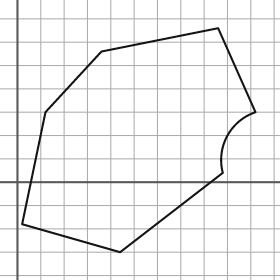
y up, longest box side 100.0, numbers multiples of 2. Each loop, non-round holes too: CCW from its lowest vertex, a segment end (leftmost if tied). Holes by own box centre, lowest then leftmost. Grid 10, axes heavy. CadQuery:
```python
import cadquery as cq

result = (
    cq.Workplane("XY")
    .moveTo(44.0, -30.0)
    .lineTo(88.0, 4.0)
    .threePointArc((90.0, 20.0), (102.0, 30.0))
    .lineTo(86.0, 66.0)
    .lineTo(36.0, 56.0)
    .lineTo(12.0, 30.0)
    .lineTo(2.0, -18.0)
    .close()
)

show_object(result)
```